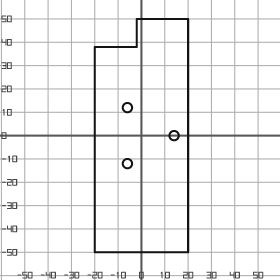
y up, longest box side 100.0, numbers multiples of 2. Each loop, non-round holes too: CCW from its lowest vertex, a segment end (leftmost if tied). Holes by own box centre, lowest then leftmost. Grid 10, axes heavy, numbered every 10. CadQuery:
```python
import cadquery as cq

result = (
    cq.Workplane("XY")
    .moveTo(-20.0, -50.0)
    .lineTo(20.0, -50.0)
    .lineTo(20.0, 50.0)
    .lineTo(-2.0, 50.0)
    .lineTo(-2.0, 38.0)
    .lineTo(-20.0, 38.0)
    .close()
    .moveTo(-6.0, -12.0)
    .circle(2.0)
    .moveTo(14.0, 0.0)
    .circle(2.0)
    .moveTo(-6.0, 12.0)
    .circle(2.0)
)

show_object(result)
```